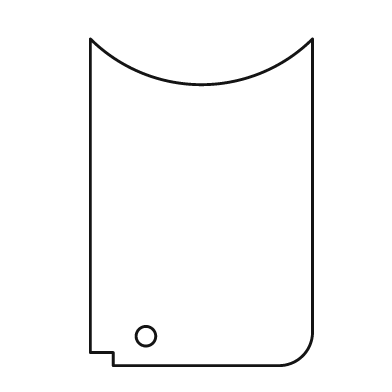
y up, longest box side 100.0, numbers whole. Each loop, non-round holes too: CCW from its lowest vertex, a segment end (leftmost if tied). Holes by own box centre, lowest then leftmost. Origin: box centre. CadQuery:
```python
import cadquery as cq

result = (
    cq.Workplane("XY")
    .moveTo(-27.0, -50.0)
    .lineTo(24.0, -50.0)
    .threePointArc((31.0, -47.0), (34.0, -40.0))
    .lineTo(34.0, 50.0)
    .threePointArc((0.0, 36.0), (-34.0, 50.0))
    .lineTo(-34.0, -46.0)
    .lineTo(-27.0, -46.0)
    .close()
    .moveTo(-17.0, -41.0)
    .circle(3.0)
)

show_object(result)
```